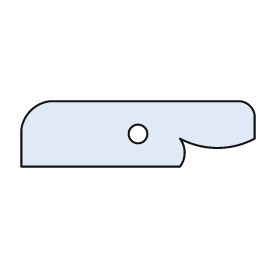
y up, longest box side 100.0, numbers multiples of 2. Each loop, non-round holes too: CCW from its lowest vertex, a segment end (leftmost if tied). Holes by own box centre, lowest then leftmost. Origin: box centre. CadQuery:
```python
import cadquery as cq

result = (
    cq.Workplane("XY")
    .moveTo(-50.0, -14.0)
    .lineTo(18.0, -14.0)
    .threePointArc((20.0, -8.0), (18.0, -2.0))
    .threePointArc((34.0, -6.0), (50.0, -2.0))
    .lineTo(50.0, 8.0)
    .threePointArc((48.0, 12.0), (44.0, 14.0))
    .lineTo(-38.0, 14.0)
    .threePointArc((-46.0, 10.0), (-50.0, 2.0))
    .close()
    .moveTo(0.0, 0.0)
    .circle(4.0)
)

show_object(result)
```